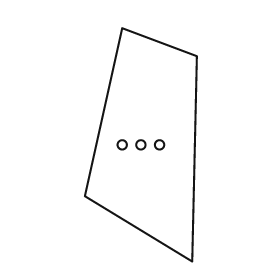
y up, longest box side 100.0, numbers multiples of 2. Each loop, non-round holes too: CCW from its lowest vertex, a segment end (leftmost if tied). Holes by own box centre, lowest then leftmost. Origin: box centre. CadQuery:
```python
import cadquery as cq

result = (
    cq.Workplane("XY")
    .moveTo(22.0, -50.0)
    .lineTo(24.0, 38.0)
    .lineTo(-8.0, 50.0)
    .lineTo(-24.0, -22.0)
    .close()
    .moveTo(-8.0, 0.0)
    .circle(2.0)
    .moveTo(0.0, 0.0)
    .circle(2.0)
    .moveTo(8.0, 0.0)
    .circle(2.0)
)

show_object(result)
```